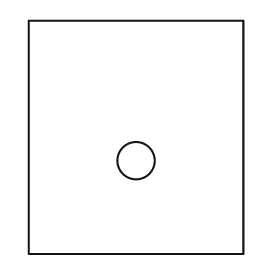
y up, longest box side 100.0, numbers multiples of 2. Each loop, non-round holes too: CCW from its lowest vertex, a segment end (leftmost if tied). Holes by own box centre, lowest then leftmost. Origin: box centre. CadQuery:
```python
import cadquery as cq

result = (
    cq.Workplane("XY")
    .moveTo(-46.0, -50.0)
    .lineTo(46.0, -50.0)
    .lineTo(46.0, 50.0)
    .lineTo(-46.0, 50.0)
    .close()
    .moveTo(0.0, -10.0)
    .circle(8.0)
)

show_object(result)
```